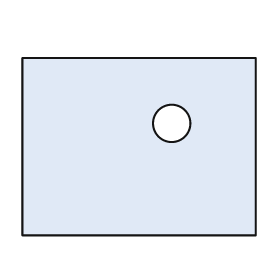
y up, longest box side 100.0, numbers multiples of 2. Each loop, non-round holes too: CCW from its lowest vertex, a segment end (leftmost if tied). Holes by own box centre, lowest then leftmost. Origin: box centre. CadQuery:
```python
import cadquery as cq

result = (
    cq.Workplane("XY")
    .moveTo(-50.0, -38.0)
    .lineTo(50.0, -38.0)
    .lineTo(50.0, 38.0)
    .lineTo(-50.0, 38.0)
    .close()
    .moveTo(14.0, 10.0)
    .circle(8.0)
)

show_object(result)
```